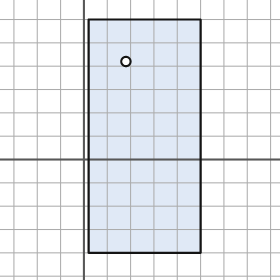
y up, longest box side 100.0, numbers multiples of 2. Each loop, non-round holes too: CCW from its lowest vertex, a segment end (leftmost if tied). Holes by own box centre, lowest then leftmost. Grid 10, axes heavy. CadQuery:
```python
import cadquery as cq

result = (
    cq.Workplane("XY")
    .moveTo(2.0, -40.0)
    .lineTo(50.0, -40.0)
    .lineTo(50.0, 60.0)
    .lineTo(2.0, 60.0)
    .close()
    .moveTo(18.0, 42.0)
    .circle(2.0)
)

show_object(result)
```